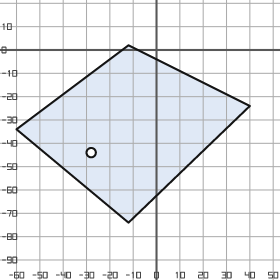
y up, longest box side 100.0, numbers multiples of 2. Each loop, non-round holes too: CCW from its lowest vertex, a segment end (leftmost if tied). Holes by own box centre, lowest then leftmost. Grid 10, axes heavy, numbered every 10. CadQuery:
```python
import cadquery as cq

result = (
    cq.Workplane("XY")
    .moveTo(-12.0, -74.0)
    .lineTo(40.0, -24.0)
    .lineTo(-12.0, 2.0)
    .lineTo(-60.0, -34.0)
    .close()
    .moveTo(-28.0, -44.0)
    .circle(2.0)
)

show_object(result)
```